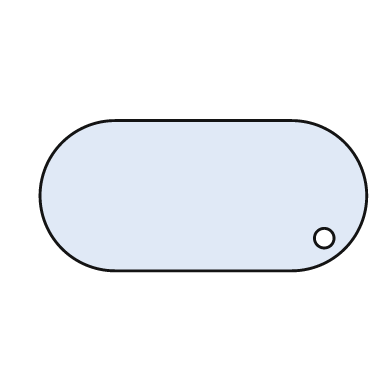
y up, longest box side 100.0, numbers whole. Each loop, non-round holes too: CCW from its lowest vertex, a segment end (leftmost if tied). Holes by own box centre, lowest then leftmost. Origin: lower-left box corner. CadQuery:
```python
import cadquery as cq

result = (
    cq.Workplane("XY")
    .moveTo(23.0, 0.0)
    .lineTo(77.0, 0.0)
    .threePointArc((100.0, 23.0), (77.0, 46.0))
    .lineTo(23.0, 46.0)
    .threePointArc((0.0, 23.0), (23.0, 0.0))
    .close()
    .moveTo(87.0, 10.0)
    .circle(3.0)
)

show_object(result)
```